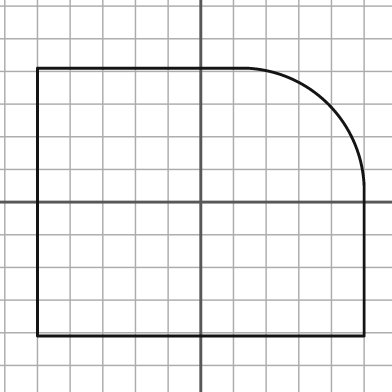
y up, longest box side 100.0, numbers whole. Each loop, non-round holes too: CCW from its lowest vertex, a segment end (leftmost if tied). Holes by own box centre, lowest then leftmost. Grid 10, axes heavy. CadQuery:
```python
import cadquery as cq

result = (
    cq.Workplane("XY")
    .moveTo(-50.0, -41.0)
    .lineTo(50.0, -41.0)
    .lineTo(50.0, 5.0)
    .threePointArc((39.0, 30.0), (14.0, 41.0))
    .lineTo(-50.0, 41.0)
    .close()
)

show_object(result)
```